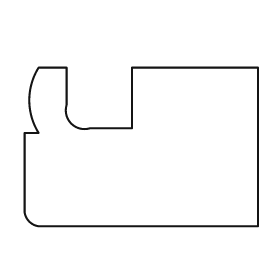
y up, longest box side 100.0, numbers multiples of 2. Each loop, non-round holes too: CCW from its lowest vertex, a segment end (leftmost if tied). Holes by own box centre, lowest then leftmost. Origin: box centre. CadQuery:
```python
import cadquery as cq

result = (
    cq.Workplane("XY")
    .moveTo(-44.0, -34.0)
    .lineTo(50.0, -34.0)
    .lineTo(50.0, 34.0)
    .lineTo(-4.0, 34.0)
    .lineTo(-4.0, 8.0)
    .lineTo(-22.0, 8.0)
    .threePointArc((-30.0, 10.0), (-32.0, 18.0))
    .lineTo(-32.0, 34.0)
    .lineTo(-44.0, 34.0)
    .threePointArc((-48.0, 20.0), (-44.0, 6.0))
    .lineTo(-50.0, 6.0)
    .lineTo(-50.0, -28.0)
    .threePointArc((-48.0, -32.0), (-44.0, -34.0))
    .close()
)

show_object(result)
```